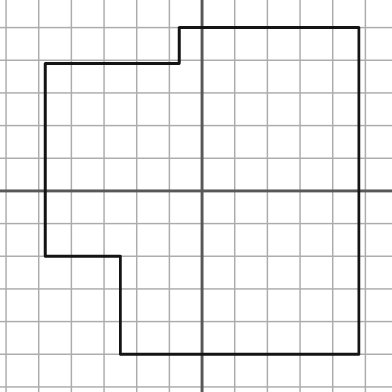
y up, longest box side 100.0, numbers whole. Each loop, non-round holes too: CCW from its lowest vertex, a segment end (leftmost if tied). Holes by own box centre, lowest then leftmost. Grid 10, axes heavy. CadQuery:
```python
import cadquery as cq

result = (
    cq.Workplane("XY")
    .moveTo(-25.0, -50.0)
    .lineTo(48.0, -50.0)
    .lineTo(48.0, 50.0)
    .lineTo(-7.0, 50.0)
    .lineTo(-7.0, 39.0)
    .lineTo(-48.0, 39.0)
    .lineTo(-48.0, -20.0)
    .lineTo(-25.0, -20.0)
    .close()
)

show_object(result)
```